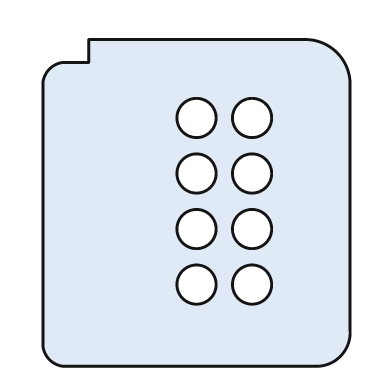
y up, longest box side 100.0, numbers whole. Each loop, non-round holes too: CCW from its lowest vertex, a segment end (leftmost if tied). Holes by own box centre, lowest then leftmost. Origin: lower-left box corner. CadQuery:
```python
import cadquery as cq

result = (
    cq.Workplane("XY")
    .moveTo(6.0, 0.0)
    .lineTo(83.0, 0.0)
    .threePointArc((91.0, 3.0), (94.0, 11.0))
    .lineTo(94.0, 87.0)
    .threePointArc((90.0, 96.0), (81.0, 100.0))
    .lineTo(14.0, 100.0)
    .lineTo(14.0, 93.0)
    .lineTo(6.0, 93.0)
    .threePointArc((2.0, 91.0), (0.0, 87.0))
    .lineTo(0.0, 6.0)
    .threePointArc((2.0, 2.0), (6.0, 0.0))
    .close()
    .moveTo(47.0, 25.0)
    .circle(6.0)
    .moveTo(64.0, 25.0)
    .circle(6.0)
    .moveTo(47.0, 42.0)
    .circle(6.0)
    .moveTo(64.0, 42.0)
    .circle(6.0)
    .moveTo(47.0, 59.0)
    .circle(6.0)
    .moveTo(64.0, 59.0)
    .circle(6.0)
    .moveTo(47.0, 76.0)
    .circle(6.0)
    .moveTo(64.0, 76.0)
    .circle(6.0)
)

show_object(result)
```